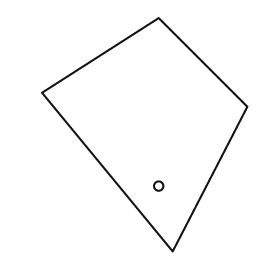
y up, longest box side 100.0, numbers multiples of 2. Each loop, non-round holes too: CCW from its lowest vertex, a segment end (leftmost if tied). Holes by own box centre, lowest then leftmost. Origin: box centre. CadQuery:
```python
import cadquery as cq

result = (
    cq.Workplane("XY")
    .moveTo(12.0, -50.0)
    .lineTo(44.0, 12.0)
    .lineTo(6.0, 50.0)
    .lineTo(-44.0, 18.0)
    .close()
    .moveTo(6.0, -22.0)
    .circle(2.0)
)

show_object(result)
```